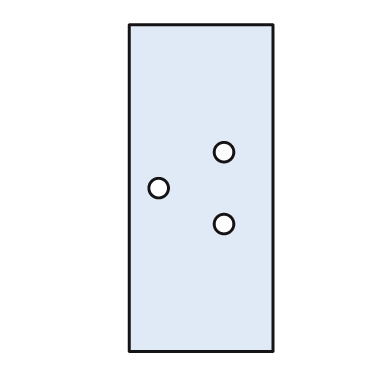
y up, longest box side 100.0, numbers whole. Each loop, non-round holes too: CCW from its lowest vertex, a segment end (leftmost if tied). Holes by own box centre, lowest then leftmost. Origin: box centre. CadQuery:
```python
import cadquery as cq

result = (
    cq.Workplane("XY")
    .moveTo(-22.0, -50.0)
    .lineTo(22.0, -50.0)
    .lineTo(22.0, 50.0)
    .lineTo(-22.0, 50.0)
    .close()
    .moveTo(7.0, -11.0)
    .circle(3.0)
    .moveTo(-13.0, 0.0)
    .circle(3.0)
    .moveTo(7.0, 11.0)
    .circle(3.0)
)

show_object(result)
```